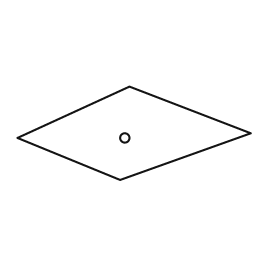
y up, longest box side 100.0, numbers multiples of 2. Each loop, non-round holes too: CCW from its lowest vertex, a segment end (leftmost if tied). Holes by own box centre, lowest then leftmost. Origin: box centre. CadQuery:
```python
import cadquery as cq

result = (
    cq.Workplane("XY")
    .moveTo(-6.0, -20.0)
    .lineTo(50.0, 0.0)
    .lineTo(-2.0, 20.0)
    .lineTo(-50.0, -2.0)
    .close()
    .moveTo(-4.0, -2.0)
    .circle(2.0)
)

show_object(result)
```